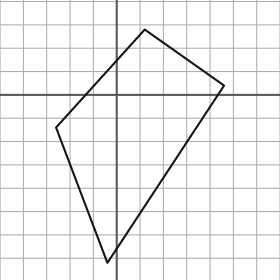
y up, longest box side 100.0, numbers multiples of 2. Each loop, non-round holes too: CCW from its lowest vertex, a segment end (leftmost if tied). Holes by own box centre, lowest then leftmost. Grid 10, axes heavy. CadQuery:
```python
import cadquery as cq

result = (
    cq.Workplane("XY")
    .moveTo(-4.0, -72.0)
    .lineTo(46.0, 4.0)
    .lineTo(12.0, 28.0)
    .lineTo(-26.0, -14.0)
    .close()
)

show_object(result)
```